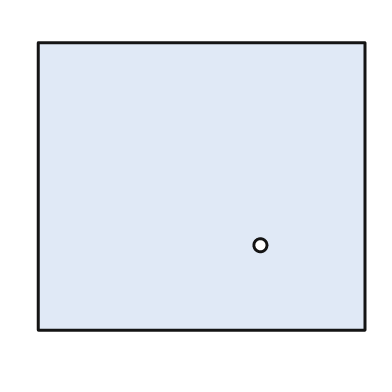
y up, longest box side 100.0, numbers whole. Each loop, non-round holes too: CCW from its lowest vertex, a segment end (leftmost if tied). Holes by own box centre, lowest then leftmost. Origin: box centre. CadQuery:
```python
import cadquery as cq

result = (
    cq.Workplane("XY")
    .moveTo(-50.0, -44.0)
    .lineTo(50.0, -44.0)
    .lineTo(50.0, 44.0)
    .lineTo(-50.0, 44.0)
    .close()
    .moveTo(18.0, -18.0)
    .circle(2.0)
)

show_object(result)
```